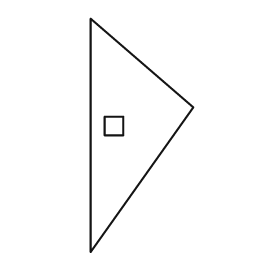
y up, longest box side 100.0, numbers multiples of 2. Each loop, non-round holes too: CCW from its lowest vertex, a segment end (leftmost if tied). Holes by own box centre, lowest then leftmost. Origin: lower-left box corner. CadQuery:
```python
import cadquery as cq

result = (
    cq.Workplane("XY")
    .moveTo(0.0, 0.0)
    .lineTo(44.0, 62.0)
    .lineTo(0.0, 100.0)
    .close()
    .moveTo(6.0, 50.0)
    .lineTo(14.0, 50.0)
    .lineTo(14.0, 58.0)
    .lineTo(6.0, 58.0)
    .close()
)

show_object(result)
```